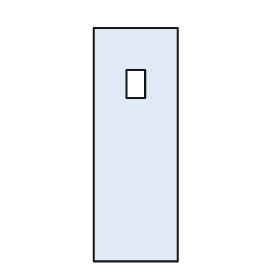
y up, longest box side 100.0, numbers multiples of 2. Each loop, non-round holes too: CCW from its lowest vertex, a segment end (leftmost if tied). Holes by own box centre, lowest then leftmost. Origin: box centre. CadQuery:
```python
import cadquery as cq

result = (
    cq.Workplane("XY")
    .moveTo(-18.0, -50.0)
    .lineTo(18.0, -50.0)
    .lineTo(18.0, 50.0)
    .lineTo(-18.0, 50.0)
    .close()
    .moveTo(-4.0, 20.0)
    .lineTo(4.0, 20.0)
    .lineTo(4.0, 32.0)
    .lineTo(-4.0, 32.0)
    .close()
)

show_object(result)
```